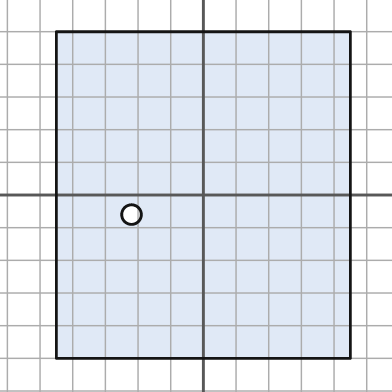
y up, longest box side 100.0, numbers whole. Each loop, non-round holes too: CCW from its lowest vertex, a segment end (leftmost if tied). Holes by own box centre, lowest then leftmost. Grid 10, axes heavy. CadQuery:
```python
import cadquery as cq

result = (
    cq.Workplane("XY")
    .moveTo(-45.0, -50.0)
    .lineTo(45.0, -50.0)
    .lineTo(45.0, 50.0)
    .lineTo(-45.0, 50.0)
    .close()
    .moveTo(-22.0, -6.0)
    .circle(3.0)
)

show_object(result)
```